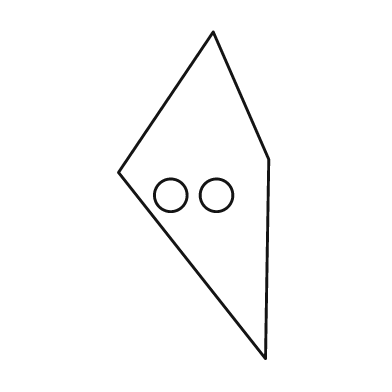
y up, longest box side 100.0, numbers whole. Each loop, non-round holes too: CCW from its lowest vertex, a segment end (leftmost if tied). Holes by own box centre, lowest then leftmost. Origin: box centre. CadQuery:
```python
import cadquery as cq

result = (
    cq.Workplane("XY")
    .moveTo(22.0, -50.0)
    .lineTo(23.0, 11.0)
    .lineTo(6.0, 50.0)
    .lineTo(-23.0, 7.0)
    .close()
    .moveTo(-7.0, 0.0)
    .circle(5.0)
    .moveTo(7.0, 0.0)
    .circle(5.0)
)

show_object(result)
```